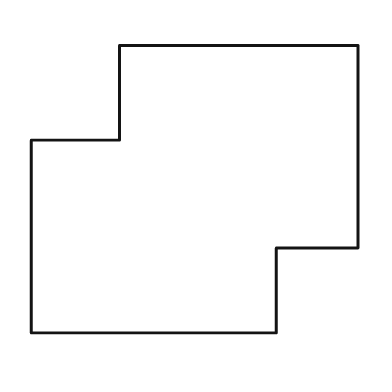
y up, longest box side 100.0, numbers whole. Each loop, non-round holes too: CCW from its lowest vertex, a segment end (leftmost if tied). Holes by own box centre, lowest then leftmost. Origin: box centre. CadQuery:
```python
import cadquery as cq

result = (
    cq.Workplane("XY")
    .moveTo(-50.0, -44.0)
    .lineTo(25.0, -44.0)
    .lineTo(25.0, -18.0)
    .lineTo(50.0, -18.0)
    .lineTo(50.0, 44.0)
    .lineTo(-23.0, 44.0)
    .lineTo(-23.0, 15.0)
    .lineTo(-50.0, 15.0)
    .close()
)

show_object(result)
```